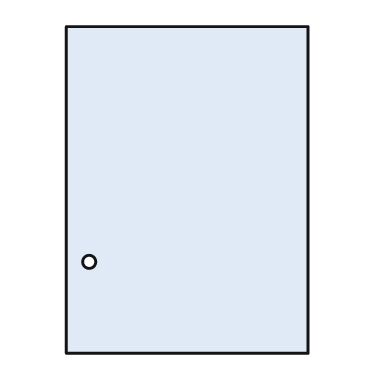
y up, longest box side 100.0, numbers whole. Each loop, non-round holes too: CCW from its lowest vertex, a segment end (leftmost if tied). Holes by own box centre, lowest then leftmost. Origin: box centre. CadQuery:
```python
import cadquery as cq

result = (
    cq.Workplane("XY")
    .moveTo(-37.0, -50.0)
    .lineTo(37.0, -50.0)
    .lineTo(37.0, 50.0)
    .lineTo(-37.0, 50.0)
    .close()
    .moveTo(-30.0, -22.0)
    .circle(2.0)
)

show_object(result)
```